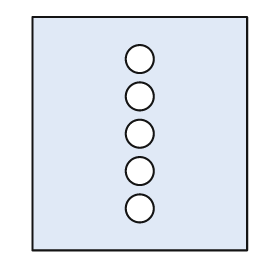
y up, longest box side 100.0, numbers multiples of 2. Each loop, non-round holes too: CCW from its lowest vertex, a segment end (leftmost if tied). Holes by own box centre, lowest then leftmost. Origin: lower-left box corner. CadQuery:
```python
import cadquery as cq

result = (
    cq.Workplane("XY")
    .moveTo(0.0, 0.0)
    .lineTo(92.0, 0.0)
    .lineTo(92.0, 100.0)
    .lineTo(0.0, 100.0)
    .close()
    .moveTo(46.0, 18.0)
    .circle(6.0)
    .moveTo(46.0, 34.0)
    .circle(6.0)
    .moveTo(46.0, 50.0)
    .circle(6.0)
    .moveTo(46.0, 66.0)
    .circle(6.0)
    .moveTo(46.0, 82.0)
    .circle(6.0)
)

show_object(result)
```